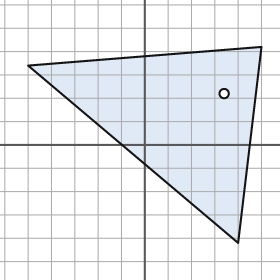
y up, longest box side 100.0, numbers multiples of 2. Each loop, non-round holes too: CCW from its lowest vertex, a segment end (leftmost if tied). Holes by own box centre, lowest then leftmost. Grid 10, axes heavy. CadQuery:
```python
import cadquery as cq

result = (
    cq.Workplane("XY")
    .moveTo(40.0, -42.0)
    .lineTo(50.0, 42.0)
    .lineTo(-50.0, 34.0)
    .close()
    .moveTo(34.0, 22.0)
    .circle(2.0)
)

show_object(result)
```